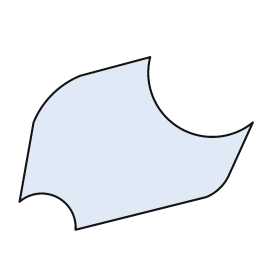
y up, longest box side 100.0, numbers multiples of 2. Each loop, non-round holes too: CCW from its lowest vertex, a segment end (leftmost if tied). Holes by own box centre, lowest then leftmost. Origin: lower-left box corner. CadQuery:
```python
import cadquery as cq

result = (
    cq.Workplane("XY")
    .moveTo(24.0, 0.0)
    .lineTo(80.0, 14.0)
    .threePointArc((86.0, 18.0), (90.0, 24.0))
    .lineTo(100.0, 46.0)
    .threePointArc((68.0, 44.0), (56.0, 74.0))
    .lineTo(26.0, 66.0)
    .threePointArc((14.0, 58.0), (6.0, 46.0))
    .lineTo(0.0, 12.0)
    .threePointArc((16.0, 14.0), (24.0, 0.0))
    .close()
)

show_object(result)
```